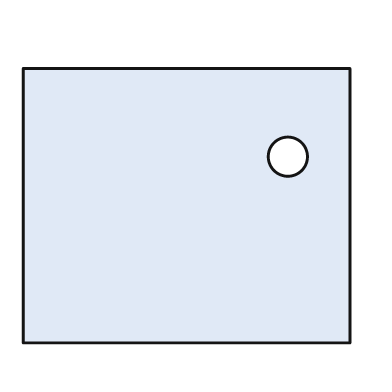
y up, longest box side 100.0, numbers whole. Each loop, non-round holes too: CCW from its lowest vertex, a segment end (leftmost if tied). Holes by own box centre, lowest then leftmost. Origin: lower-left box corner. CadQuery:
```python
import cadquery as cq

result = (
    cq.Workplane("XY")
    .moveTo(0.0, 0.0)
    .lineTo(100.0, 0.0)
    .lineTo(100.0, 84.0)
    .lineTo(0.0, 84.0)
    .close()
    .moveTo(81.0, 57.0)
    .circle(6.0)
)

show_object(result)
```